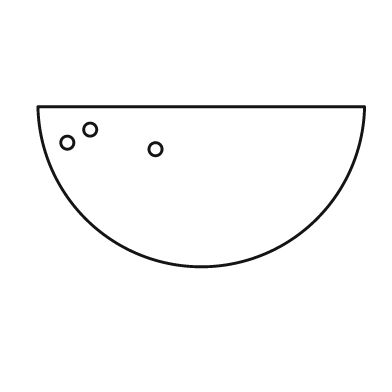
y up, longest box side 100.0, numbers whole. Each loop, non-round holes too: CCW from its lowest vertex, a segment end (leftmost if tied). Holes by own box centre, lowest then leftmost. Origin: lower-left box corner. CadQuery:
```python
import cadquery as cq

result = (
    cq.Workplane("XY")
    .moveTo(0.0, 49.0)
    .threePointArc((50.0, 0.0), (100.0, 49.0))
    .close()
    .moveTo(36.0, 36.0)
    .circle(2.0)
    .moveTo(9.0, 38.0)
    .circle(2.0)
    .moveTo(16.0, 42.0)
    .circle(2.0)
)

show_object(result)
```